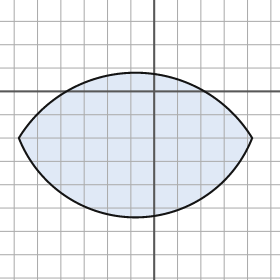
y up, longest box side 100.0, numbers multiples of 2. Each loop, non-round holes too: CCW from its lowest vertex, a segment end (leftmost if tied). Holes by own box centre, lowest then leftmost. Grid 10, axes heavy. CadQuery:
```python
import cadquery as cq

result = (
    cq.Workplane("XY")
    .moveTo(-58.0, -20.0)
    .threePointArc((-8.0, -54.0), (42.0, -20.0))
    .threePointArc((-8.0, 8.0), (-58.0, -20.0))
    .close()
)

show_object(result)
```